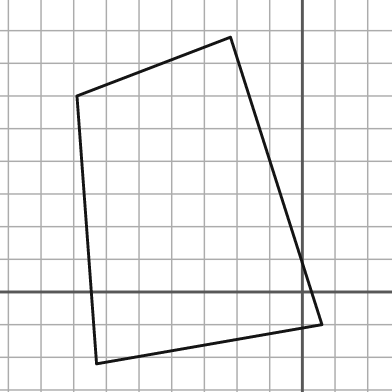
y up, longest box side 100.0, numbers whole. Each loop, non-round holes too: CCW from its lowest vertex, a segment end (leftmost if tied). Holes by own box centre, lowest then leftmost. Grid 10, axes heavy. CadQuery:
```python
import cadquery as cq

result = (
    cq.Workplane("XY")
    .moveTo(-63.0, -22.0)
    .lineTo(6.0, -10.0)
    .lineTo(-22.0, 78.0)
    .lineTo(-69.0, 60.0)
    .close()
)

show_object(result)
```